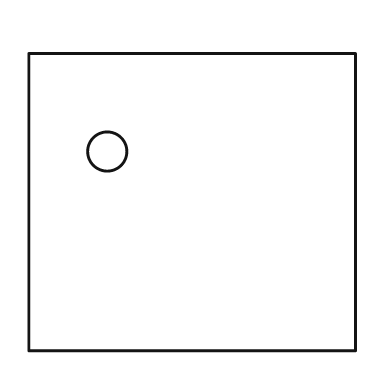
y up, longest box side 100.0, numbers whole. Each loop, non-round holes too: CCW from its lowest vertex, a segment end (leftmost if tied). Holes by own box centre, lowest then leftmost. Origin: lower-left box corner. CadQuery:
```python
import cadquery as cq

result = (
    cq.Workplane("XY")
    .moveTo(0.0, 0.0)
    .lineTo(100.0, 0.0)
    .lineTo(100.0, 91.0)
    .lineTo(0.0, 91.0)
    .close()
    .moveTo(24.0, 61.0)
    .circle(6.0)
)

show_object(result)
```